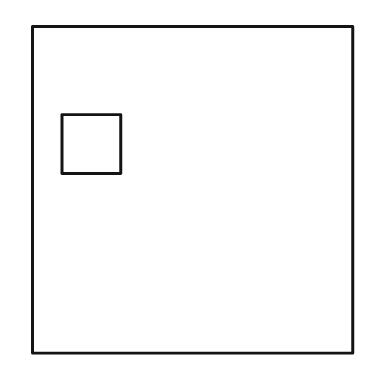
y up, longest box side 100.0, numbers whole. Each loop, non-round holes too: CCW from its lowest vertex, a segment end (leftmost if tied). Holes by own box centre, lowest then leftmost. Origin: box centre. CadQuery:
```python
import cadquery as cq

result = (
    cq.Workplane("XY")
    .moveTo(-49.0, -50.0)
    .lineTo(49.0, -50.0)
    .lineTo(49.0, 50.0)
    .lineTo(-49.0, 50.0)
    .close()
    .moveTo(-40.0, 5.0)
    .lineTo(-22.0, 5.0)
    .lineTo(-22.0, 23.0)
    .lineTo(-40.0, 23.0)
    .close()
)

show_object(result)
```